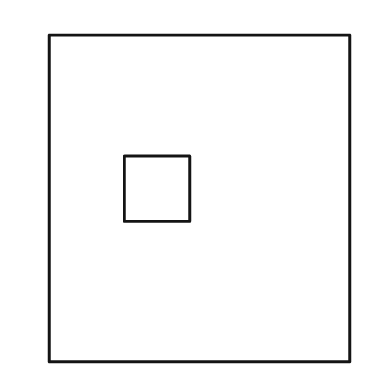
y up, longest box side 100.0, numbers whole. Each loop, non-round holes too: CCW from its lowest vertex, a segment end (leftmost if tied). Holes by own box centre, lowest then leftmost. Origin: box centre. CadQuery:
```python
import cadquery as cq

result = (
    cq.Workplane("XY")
    .moveTo(-46.0, -50.0)
    .lineTo(46.0, -50.0)
    .lineTo(46.0, 50.0)
    .lineTo(-46.0, 50.0)
    .close()
    .moveTo(-23.0, -7.0)
    .lineTo(-3.0, -7.0)
    .lineTo(-3.0, 13.0)
    .lineTo(-23.0, 13.0)
    .close()
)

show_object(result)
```